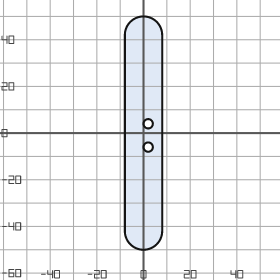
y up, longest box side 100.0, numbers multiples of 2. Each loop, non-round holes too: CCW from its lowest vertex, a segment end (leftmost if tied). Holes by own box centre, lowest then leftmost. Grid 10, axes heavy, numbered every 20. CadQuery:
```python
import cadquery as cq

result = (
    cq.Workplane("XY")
    .moveTo(-8.0, -42.0)
    .threePointArc((0.0, -50.0), (8.0, -42.0))
    .lineTo(8.0, 42.0)
    .threePointArc((0.0, 50.0), (-8.0, 42.0))
    .close()
    .moveTo(2.0, -6.0)
    .circle(2.0)
    .moveTo(2.0, 4.0)
    .circle(2.0)
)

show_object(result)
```